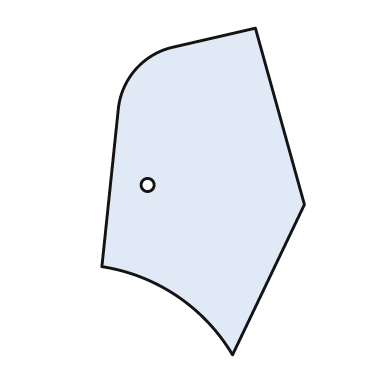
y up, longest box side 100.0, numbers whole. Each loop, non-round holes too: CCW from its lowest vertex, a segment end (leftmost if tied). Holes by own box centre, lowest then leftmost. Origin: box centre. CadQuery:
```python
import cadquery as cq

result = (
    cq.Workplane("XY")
    .moveTo(9.0, -50.0)
    .lineTo(31.0, -4.0)
    .lineTo(16.0, 50.0)
    .lineTo(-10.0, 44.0)
    .threePointArc((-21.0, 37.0), (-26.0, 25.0))
    .lineTo(-31.0, -23.0)
    .threePointArc((-8.0, -32.0), (9.0, -50.0))
    .close()
    .moveTo(-17.0, 2.0)
    .circle(2.0)
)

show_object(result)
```